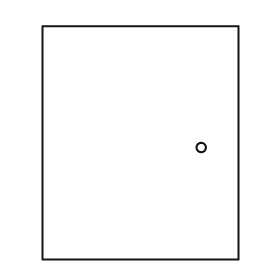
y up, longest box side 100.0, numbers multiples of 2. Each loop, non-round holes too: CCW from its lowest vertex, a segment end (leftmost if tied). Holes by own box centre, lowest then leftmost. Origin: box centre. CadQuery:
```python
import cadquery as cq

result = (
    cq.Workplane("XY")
    .moveTo(-42.0, -50.0)
    .lineTo(42.0, -50.0)
    .lineTo(42.0, 50.0)
    .lineTo(-42.0, 50.0)
    .close()
    .moveTo(26.0, -2.0)
    .circle(2.0)
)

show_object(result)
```